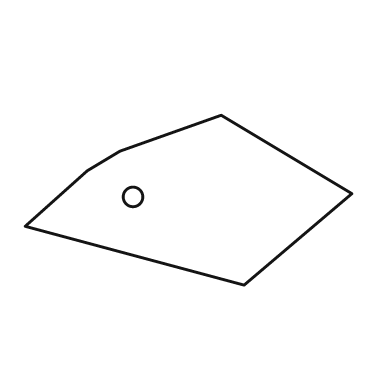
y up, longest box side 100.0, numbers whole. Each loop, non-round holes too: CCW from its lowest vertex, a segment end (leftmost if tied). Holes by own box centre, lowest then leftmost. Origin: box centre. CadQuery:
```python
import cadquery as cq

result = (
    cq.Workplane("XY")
    .moveTo(17.0, -26.0)
    .lineTo(50.0, 2.0)
    .lineTo(10.0, 26.0)
    .lineTo(-21.0, 15.0)
    .lineTo(-31.0, 9.0)
    .lineTo(-50.0, -8.0)
    .close()
    .moveTo(-17.0, 1.0)
    .circle(3.0)
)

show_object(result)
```